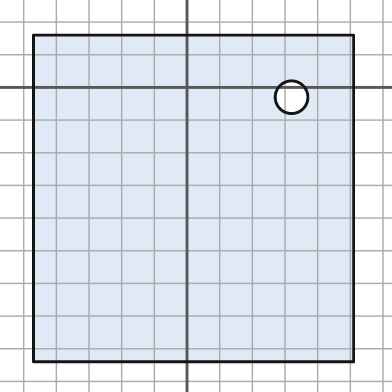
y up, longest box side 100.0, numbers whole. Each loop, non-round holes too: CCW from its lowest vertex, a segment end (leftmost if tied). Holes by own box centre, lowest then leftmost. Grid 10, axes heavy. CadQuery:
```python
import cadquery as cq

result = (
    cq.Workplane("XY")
    .moveTo(-47.0, -84.0)
    .lineTo(51.0, -84.0)
    .lineTo(51.0, 16.0)
    .lineTo(-47.0, 16.0)
    .close()
    .moveTo(32.0, -3.0)
    .circle(5.0)
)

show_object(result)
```